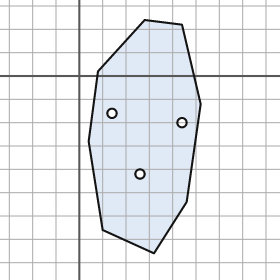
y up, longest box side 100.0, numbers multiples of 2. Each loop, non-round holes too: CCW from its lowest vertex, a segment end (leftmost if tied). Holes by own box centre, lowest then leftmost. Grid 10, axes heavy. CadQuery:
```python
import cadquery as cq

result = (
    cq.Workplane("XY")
    .moveTo(32.0, -76.0)
    .lineTo(46.0, -54.0)
    .lineTo(52.0, -12.0)
    .lineTo(44.0, 22.0)
    .lineTo(28.0, 24.0)
    .lineTo(8.0, 2.0)
    .lineTo(4.0, -28.0)
    .lineTo(10.0, -66.0)
    .close()
    .moveTo(26.0, -42.0)
    .circle(2.0)
    .moveTo(44.0, -20.0)
    .circle(2.0)
    .moveTo(14.0, -16.0)
    .circle(2.0)
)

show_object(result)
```